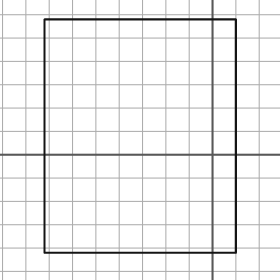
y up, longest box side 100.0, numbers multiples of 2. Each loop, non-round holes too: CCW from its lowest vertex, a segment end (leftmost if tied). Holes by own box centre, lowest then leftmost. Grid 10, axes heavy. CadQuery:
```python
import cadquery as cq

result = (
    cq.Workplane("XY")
    .moveTo(-72.0, -42.0)
    .lineTo(10.0, -42.0)
    .lineTo(10.0, 58.0)
    .lineTo(-72.0, 58.0)
    .close()
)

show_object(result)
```